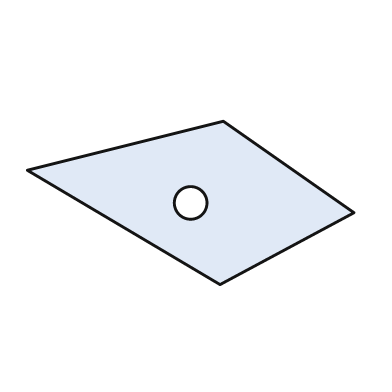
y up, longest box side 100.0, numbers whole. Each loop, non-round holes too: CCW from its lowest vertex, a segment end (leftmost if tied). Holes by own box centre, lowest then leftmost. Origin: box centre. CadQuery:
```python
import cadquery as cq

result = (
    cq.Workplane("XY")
    .moveTo(9.0, -25.0)
    .lineTo(50.0, -3.0)
    .lineTo(10.0, 25.0)
    .lineTo(-50.0, 10.0)
    .close()
    .moveTo(0.0, 0.0)
    .circle(5.0)
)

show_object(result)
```